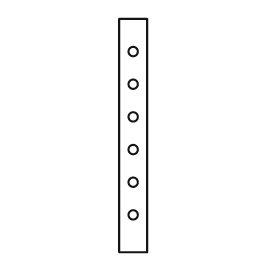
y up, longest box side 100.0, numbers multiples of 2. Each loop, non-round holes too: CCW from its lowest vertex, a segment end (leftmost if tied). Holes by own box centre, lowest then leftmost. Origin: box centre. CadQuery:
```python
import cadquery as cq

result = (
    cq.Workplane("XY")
    .moveTo(-6.0, -50.0)
    .lineTo(6.0, -50.0)
    .lineTo(6.0, 50.0)
    .lineTo(-6.0, 50.0)
    .close()
    .moveTo(0.0, -34.0)
    .circle(2.0)
    .moveTo(0.0, -20.0)
    .circle(2.0)
    .moveTo(0.0, -6.0)
    .circle(2.0)
    .moveTo(0.0, 8.0)
    .circle(2.0)
    .moveTo(0.0, 22.0)
    .circle(2.0)
    .moveTo(0.0, 36.0)
    .circle(2.0)
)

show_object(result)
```